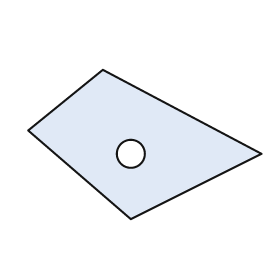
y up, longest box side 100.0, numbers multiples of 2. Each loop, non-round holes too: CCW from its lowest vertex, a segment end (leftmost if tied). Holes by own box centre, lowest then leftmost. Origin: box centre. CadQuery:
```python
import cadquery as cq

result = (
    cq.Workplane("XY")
    .moveTo(-6.0, -32.0)
    .lineTo(50.0, -4.0)
    .lineTo(-18.0, 32.0)
    .lineTo(-50.0, 6.0)
    .close()
    .moveTo(-6.0, -4.0)
    .circle(6.0)
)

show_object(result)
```